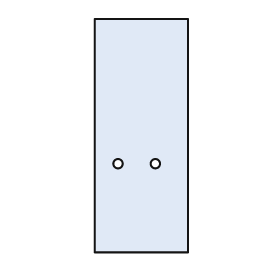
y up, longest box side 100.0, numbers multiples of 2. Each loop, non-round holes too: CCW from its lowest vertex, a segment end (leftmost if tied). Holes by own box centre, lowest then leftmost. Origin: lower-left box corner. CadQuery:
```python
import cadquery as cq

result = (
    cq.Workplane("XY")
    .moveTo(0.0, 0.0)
    .lineTo(40.0, 0.0)
    .lineTo(40.0, 100.0)
    .lineTo(0.0, 100.0)
    .close()
    .moveTo(10.0, 38.0)
    .circle(2.0)
    .moveTo(26.0, 38.0)
    .circle(2.0)
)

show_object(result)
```